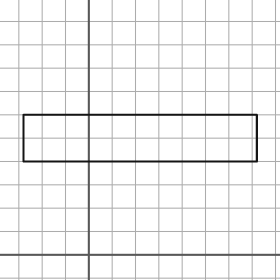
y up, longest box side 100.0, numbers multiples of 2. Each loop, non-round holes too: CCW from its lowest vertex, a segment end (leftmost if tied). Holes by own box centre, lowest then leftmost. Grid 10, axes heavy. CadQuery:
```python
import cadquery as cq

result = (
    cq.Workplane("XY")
    .moveTo(-28.0, 40.0)
    .lineTo(72.0, 40.0)
    .lineTo(72.0, 60.0)
    .lineTo(-28.0, 60.0)
    .close()
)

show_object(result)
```